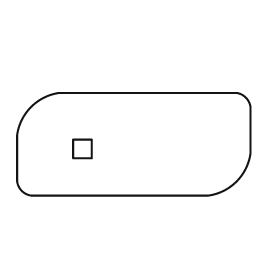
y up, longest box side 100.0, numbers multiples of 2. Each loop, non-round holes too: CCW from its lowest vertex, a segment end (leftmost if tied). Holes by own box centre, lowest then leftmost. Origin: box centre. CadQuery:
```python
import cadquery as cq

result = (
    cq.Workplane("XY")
    .moveTo(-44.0, -22.0)
    .lineTo(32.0, -22.0)
    .threePointArc((44.0, -16.0), (50.0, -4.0))
    .lineTo(50.0, 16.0)
    .threePointArc((48.0, 20.0), (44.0, 22.0))
    .lineTo(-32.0, 22.0)
    .threePointArc((-44.0, 16.0), (-50.0, 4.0))
    .lineTo(-50.0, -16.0)
    .threePointArc((-48.0, -20.0), (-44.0, -22.0))
    .close()
    .moveTo(-26.0, -6.0)
    .lineTo(-18.0, -6.0)
    .lineTo(-18.0, 2.0)
    .lineTo(-26.0, 2.0)
    .close()
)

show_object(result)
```